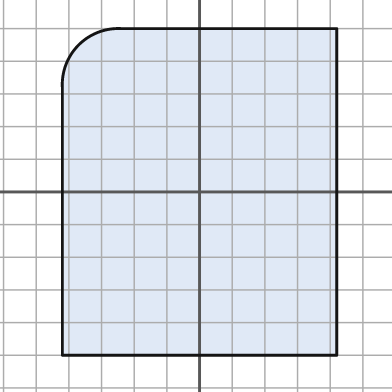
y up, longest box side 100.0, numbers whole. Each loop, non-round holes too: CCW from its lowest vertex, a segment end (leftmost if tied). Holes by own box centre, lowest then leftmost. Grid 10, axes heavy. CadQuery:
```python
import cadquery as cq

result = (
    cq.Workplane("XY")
    .moveTo(-42.0, -50.0)
    .lineTo(42.0, -50.0)
    .lineTo(42.0, 50.0)
    .lineTo(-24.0, 50.0)
    .threePointArc((-37.0, 45.0), (-42.0, 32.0))
    .close()
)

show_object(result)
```